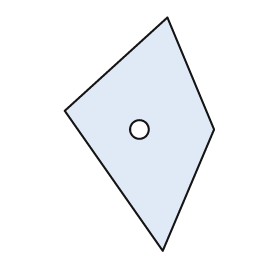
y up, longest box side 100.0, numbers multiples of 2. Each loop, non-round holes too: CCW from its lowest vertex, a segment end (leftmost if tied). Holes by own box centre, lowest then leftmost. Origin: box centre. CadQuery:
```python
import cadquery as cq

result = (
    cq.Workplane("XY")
    .moveTo(10.0, -50.0)
    .lineTo(32.0, 2.0)
    .lineTo(12.0, 50.0)
    .lineTo(-32.0, 10.0)
    .close()
    .moveTo(0.0, 2.0)
    .circle(4.0)
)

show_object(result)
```